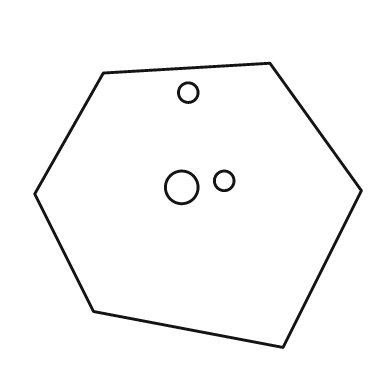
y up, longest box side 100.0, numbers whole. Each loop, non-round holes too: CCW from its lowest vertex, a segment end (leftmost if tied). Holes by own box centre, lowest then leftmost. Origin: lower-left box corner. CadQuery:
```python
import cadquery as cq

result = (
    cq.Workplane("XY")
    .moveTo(76.0, 0.0)
    .lineTo(100.0, 48.0)
    .lineTo(72.0, 87.0)
    .lineTo(21.0, 84.0)
    .lineTo(0.0, 47.0)
    .lineTo(18.0, 11.0)
    .close()
    .moveTo(45.0, 49.0)
    .circle(5.0)
    .moveTo(58.0, 51.0)
    .circle(3.0)
    .moveTo(47.0, 78.0)
    .circle(3.0)
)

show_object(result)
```